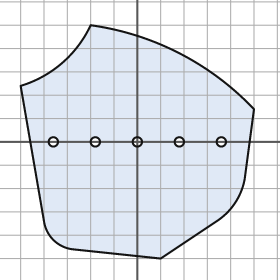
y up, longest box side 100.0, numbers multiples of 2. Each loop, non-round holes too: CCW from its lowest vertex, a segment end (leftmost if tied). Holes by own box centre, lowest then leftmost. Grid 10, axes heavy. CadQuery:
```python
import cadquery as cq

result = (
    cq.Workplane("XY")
    .moveTo(10.0, -50.0)
    .lineTo(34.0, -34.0)
    .threePointArc((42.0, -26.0), (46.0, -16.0))
    .lineTo(50.0, 14.0)
    .threePointArc((18.0, 38.0), (-20.0, 50.0))
    .threePointArc((-32.0, 34.0), (-50.0, 24.0))
    .lineTo(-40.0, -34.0)
    .threePointArc((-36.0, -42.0), (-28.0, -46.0))
    .close()
    .moveTo(-36.0, 0.0)
    .circle(2.0)
    .moveTo(-18.0, 0.0)
    .circle(2.0)
    .moveTo(0.0, 0.0)
    .circle(2.0)
    .moveTo(18.0, 0.0)
    .circle(2.0)
    .moveTo(36.0, 0.0)
    .circle(2.0)
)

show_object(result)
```